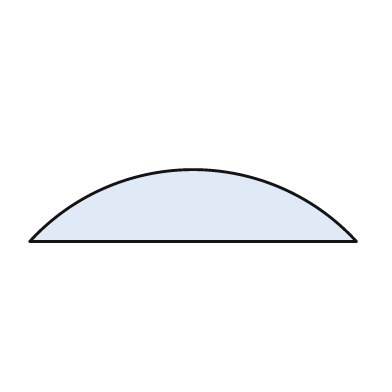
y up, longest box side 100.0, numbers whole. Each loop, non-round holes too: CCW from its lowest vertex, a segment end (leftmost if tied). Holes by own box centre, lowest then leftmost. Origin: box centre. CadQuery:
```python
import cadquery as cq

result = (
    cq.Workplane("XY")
    .moveTo(-50.0, -11.0)
    .lineTo(50.0, -11.0)
    .threePointArc((0.0, 11.0), (-50.0, -11.0))
    .close()
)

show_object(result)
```